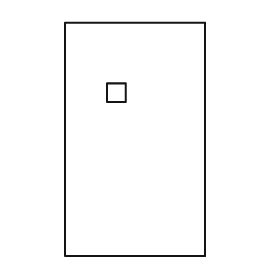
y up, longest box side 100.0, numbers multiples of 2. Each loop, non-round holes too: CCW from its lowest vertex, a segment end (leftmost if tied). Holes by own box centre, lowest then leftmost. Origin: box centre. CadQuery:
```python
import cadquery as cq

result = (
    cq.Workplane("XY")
    .moveTo(-30.0, -50.0)
    .lineTo(30.0, -50.0)
    .lineTo(30.0, 50.0)
    .lineTo(-30.0, 50.0)
    .close()
    .moveTo(-12.0, 16.0)
    .lineTo(-4.0, 16.0)
    .lineTo(-4.0, 24.0)
    .lineTo(-12.0, 24.0)
    .close()
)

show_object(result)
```